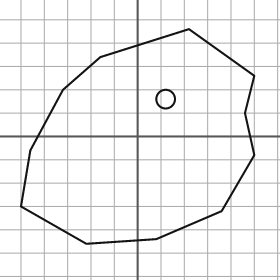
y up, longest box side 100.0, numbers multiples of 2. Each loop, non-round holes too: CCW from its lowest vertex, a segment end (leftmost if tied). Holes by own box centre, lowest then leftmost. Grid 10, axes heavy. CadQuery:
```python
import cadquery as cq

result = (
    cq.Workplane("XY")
    .moveTo(-22.0, -46.0)
    .lineTo(8.0, -44.0)
    .lineTo(36.0, -32.0)
    .lineTo(50.0, -8.0)
    .lineTo(46.0, 10.0)
    .lineTo(50.0, 26.0)
    .lineTo(22.0, 46.0)
    .lineTo(-16.0, 34.0)
    .lineTo(-32.0, 20.0)
    .lineTo(-46.0, -6.0)
    .lineTo(-50.0, -30.0)
    .close()
    .moveTo(12.0, 16.0)
    .circle(4.0)
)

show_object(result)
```